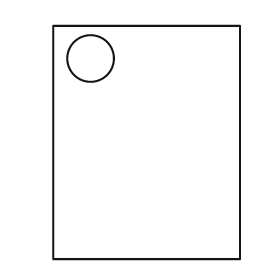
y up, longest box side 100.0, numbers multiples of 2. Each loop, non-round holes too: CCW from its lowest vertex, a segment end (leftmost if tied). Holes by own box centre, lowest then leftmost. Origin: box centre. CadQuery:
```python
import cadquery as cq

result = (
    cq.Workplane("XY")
    .moveTo(-40.0, -50.0)
    .lineTo(40.0, -50.0)
    .lineTo(40.0, 50.0)
    .lineTo(-40.0, 50.0)
    .close()
    .moveTo(-24.0, 36.0)
    .circle(10.0)
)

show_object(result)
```